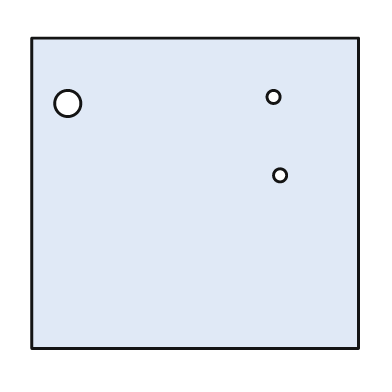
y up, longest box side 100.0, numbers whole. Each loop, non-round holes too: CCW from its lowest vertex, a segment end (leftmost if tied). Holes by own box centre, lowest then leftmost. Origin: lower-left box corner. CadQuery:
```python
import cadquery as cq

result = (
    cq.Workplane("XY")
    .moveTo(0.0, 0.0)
    .lineTo(100.0, 0.0)
    .lineTo(100.0, 95.0)
    .lineTo(0.0, 95.0)
    .close()
    .moveTo(76.0, 53.0)
    .circle(2.0)
    .moveTo(11.0, 75.0)
    .circle(4.0)
    .moveTo(74.0, 77.0)
    .circle(2.0)
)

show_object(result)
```